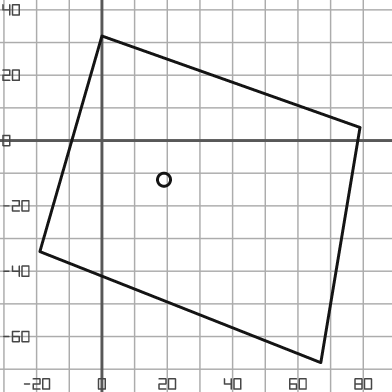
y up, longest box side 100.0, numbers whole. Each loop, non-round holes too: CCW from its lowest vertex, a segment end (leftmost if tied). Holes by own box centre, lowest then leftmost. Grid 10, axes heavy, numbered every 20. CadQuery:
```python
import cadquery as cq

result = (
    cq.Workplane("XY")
    .moveTo(67.0, -68.0)
    .lineTo(79.0, 4.0)
    .lineTo(0.0, 32.0)
    .lineTo(-19.0, -34.0)
    .close()
    .moveTo(19.0, -12.0)
    .circle(2.0)
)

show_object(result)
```